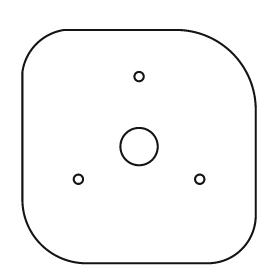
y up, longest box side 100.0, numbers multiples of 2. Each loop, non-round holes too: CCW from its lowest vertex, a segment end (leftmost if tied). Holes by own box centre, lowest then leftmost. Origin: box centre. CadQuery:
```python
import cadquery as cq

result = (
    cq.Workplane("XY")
    .moveTo(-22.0, -50.0)
    .lineTo(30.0, -50.0)
    .threePointArc((44.0, -44.0), (50.0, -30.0))
    .lineTo(50.0, 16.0)
    .threePointArc((40.0, 40.0), (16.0, 50.0))
    .lineTo(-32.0, 50.0)
    .threePointArc((-44.0, 44.0), (-50.0, 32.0))
    .lineTo(-50.0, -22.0)
    .threePointArc((-42.0, -42.0), (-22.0, -50.0))
    .close()
    .moveTo(-26.0, -14.0)
    .circle(2.0)
    .moveTo(26.0, -14.0)
    .circle(2.0)
    .moveTo(0.0, 0.0)
    .circle(8.0)
    .moveTo(0.0, 30.0)
    .circle(2.0)
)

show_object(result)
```